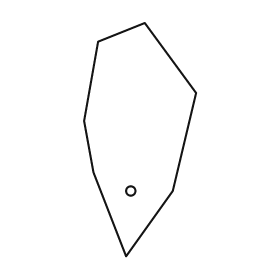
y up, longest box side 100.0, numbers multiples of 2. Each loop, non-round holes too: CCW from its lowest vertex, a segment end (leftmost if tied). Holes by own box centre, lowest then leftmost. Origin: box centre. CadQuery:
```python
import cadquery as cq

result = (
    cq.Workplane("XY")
    .moveTo(-6.0, -50.0)
    .lineTo(14.0, -22.0)
    .lineTo(24.0, 20.0)
    .lineTo(2.0, 50.0)
    .lineTo(-18.0, 42.0)
    .lineTo(-24.0, 8.0)
    .lineTo(-20.0, -14.0)
    .close()
    .moveTo(-4.0, -22.0)
    .circle(2.0)
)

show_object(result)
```